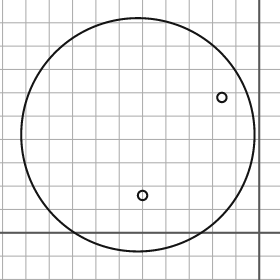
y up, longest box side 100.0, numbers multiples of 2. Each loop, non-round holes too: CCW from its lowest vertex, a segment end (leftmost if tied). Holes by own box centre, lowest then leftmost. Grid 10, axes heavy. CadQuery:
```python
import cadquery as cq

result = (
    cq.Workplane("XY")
    .moveTo(-52.0, 42.0)
    .circle(50.0)
    .moveTo(-50.0, 16.0)
    .circle(2.0)
    .moveTo(-16.0, 58.0)
    .circle(2.0)
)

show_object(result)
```